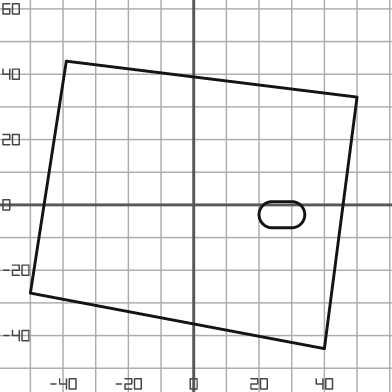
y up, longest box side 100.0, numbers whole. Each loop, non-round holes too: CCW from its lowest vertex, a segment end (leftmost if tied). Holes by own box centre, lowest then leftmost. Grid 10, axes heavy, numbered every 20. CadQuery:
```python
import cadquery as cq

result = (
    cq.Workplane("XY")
    .moveTo(40.0, -44.0)
    .lineTo(50.0, 33.0)
    .lineTo(-39.0, 44.0)
    .lineTo(-50.0, -27.0)
    .close()
    .moveTo(24.0, -7.0)
    .lineTo(30.0, -7.0)
    .threePointArc((34.0, -3.0), (30.0, 1.0))
    .lineTo(24.0, 1.0)
    .threePointArc((20.0, -3.0), (24.0, -7.0))
    .close()
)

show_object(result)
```